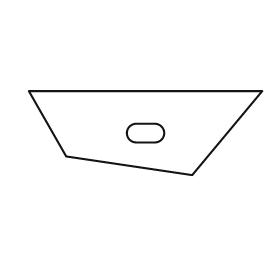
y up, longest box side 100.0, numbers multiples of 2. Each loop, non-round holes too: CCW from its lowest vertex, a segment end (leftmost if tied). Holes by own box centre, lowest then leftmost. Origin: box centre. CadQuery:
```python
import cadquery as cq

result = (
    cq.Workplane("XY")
    .moveTo(20.0, -18.0)
    .lineTo(50.0, 18.0)
    .lineTo(-50.0, 18.0)
    .lineTo(-34.0, -10.0)
    .close()
    .moveTo(-4.0, -4.0)
    .lineTo(4.0, -4.0)
    .threePointArc((8.0, 0.0), (4.0, 4.0))
    .lineTo(-4.0, 4.0)
    .threePointArc((-8.0, 0.0), (-4.0, -4.0))
    .close()
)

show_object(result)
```